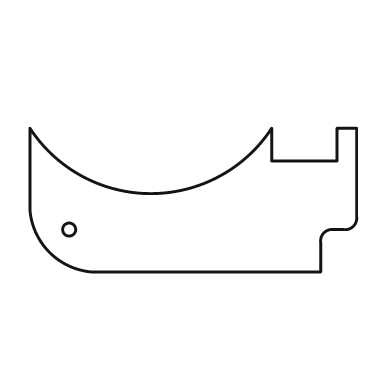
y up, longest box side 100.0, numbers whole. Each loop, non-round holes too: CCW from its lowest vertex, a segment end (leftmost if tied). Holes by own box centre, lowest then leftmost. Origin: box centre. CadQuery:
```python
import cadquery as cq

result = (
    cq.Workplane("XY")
    .moveTo(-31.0, -22.0)
    .lineTo(39.0, -22.0)
    .lineTo(39.0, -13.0)
    .threePointArc((40.0, -10.0), (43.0, -9.0))
    .lineTo(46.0, -9.0)
    .threePointArc((49.0, -8.0), (50.0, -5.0))
    .lineTo(50.0, 22.0)
    .lineTo(44.0, 22.0)
    .lineTo(44.0, 12.0)
    .lineTo(24.0, 12.0)
    .lineTo(24.0, 22.0)
    .threePointArc((-13.0, 2.0), (-50.0, 22.0))
    .lineTo(-50.0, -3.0)
    .threePointArc((-44.0, -16.0), (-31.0, -22.0))
    .close()
    .moveTo(-38.0, -9.0)
    .circle(2.0)
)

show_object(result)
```